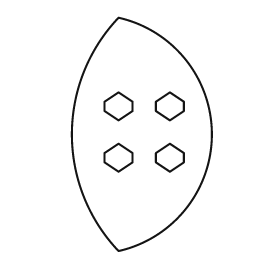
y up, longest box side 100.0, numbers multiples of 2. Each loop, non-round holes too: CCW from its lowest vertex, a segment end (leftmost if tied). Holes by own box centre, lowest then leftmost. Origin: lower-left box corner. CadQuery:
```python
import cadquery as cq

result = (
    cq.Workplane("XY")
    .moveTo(20.0, 0.0)
    .threePointArc((60.0, 50.0), (20.0, 100.0))
    .threePointArc((0.0, 50.0), (20.0, 0.0))
    .close()
    .moveTo(20.0, 34.0)
    .lineTo(26.0, 38.0)
    .lineTo(26.0, 42.0)
    .lineTo(20.0, 46.0)
    .lineTo(14.0, 42.0)
    .lineTo(14.0, 38.0)
    .close()
    .moveTo(42.0, 34.0)
    .lineTo(48.0, 38.0)
    .lineTo(48.0, 42.0)
    .lineTo(42.0, 46.0)
    .lineTo(36.0, 42.0)
    .lineTo(36.0, 38.0)
    .close()
    .moveTo(20.0, 56.0)
    .lineTo(26.0, 60.0)
    .lineTo(26.0, 64.0)
    .lineTo(20.0, 68.0)
    .lineTo(14.0, 64.0)
    .lineTo(14.0, 60.0)
    .close()
    .moveTo(42.0, 56.0)
    .lineTo(48.0, 60.0)
    .lineTo(48.0, 64.0)
    .lineTo(42.0, 68.0)
    .lineTo(36.0, 64.0)
    .lineTo(36.0, 60.0)
    .close()
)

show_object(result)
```